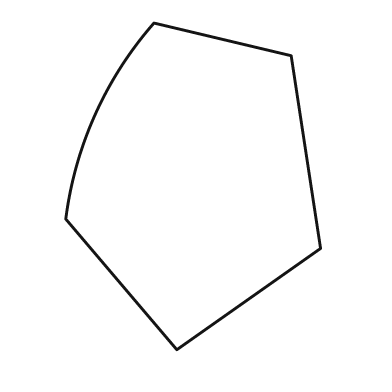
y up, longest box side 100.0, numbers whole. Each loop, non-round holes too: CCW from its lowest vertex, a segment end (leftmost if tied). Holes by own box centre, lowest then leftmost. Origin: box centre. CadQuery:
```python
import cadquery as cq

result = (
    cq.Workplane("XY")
    .moveTo(-5.0, -50.0)
    .lineTo(39.0, -19.0)
    .lineTo(30.0, 40.0)
    .lineTo(-12.0, 50.0)
    .threePointArc((-30.0, 22.0), (-39.0, -10.0))
    .close()
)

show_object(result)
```